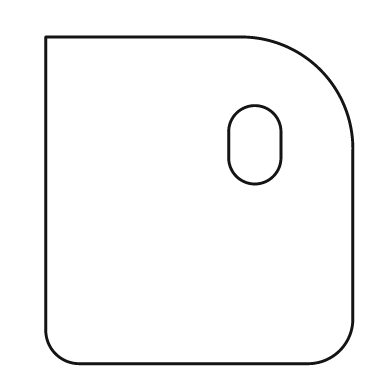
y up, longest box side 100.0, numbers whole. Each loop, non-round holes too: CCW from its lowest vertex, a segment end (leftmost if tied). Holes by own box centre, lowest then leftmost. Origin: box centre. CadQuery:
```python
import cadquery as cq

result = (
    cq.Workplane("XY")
    .moveTo(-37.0, -50.0)
    .lineTo(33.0, -50.0)
    .threePointArc((43.0, -46.0), (47.0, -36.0))
    .lineTo(47.0, 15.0)
    .threePointArc((37.0, 40.0), (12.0, 50.0))
    .lineTo(-47.0, 50.0)
    .lineTo(-47.0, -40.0)
    .threePointArc((-44.0, -47.0), (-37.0, -50.0))
    .close()
    .moveTo(9.0, 13.0)
    .threePointArc((17.0, 5.0), (25.0, 13.0))
    .lineTo(25.0, 21.0)
    .threePointArc((17.0, 29.0), (9.0, 21.0))
    .close()
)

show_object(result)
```